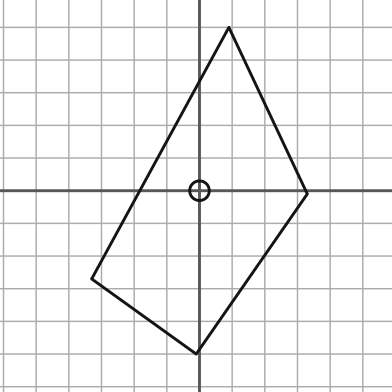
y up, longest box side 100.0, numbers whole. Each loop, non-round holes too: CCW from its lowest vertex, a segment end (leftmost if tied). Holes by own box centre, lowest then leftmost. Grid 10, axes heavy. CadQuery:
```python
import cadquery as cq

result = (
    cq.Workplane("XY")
    .moveTo(-1.0, -50.0)
    .lineTo(33.0, -1.0)
    .lineTo(9.0, 50.0)
    .lineTo(-33.0, -27.0)
    .close()
    .moveTo(0.0, 0.0)
    .circle(3.0)
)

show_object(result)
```